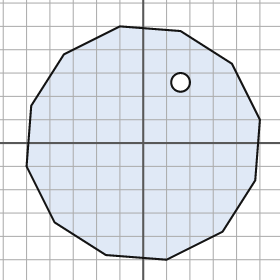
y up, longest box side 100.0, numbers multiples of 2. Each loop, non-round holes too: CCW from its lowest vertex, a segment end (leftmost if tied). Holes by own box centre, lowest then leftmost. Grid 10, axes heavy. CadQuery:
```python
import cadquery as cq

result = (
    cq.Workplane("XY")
    .moveTo(10.0, -50.0)
    .lineTo(34.0, -38.0)
    .lineTo(48.0, -16.0)
    .lineTo(50.0, 10.0)
    .lineTo(38.0, 34.0)
    .lineTo(16.0, 48.0)
    .lineTo(-10.0, 50.0)
    .lineTo(-34.0, 38.0)
    .lineTo(-48.0, 16.0)
    .lineTo(-50.0, -10.0)
    .lineTo(-38.0, -34.0)
    .lineTo(-16.0, -48.0)
    .close()
    .moveTo(16.0, 26.0)
    .circle(4.0)
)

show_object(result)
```